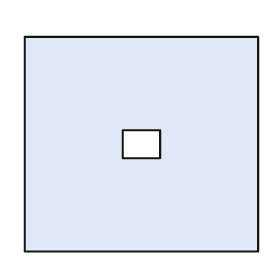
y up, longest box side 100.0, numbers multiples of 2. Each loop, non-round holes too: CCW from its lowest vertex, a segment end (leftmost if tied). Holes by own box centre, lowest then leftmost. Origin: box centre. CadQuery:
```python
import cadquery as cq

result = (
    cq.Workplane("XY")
    .moveTo(-50.0, -46.0)
    .lineTo(50.0, -46.0)
    .lineTo(50.0, 46.0)
    .lineTo(-50.0, 46.0)
    .close()
    .moveTo(-8.0, -6.0)
    .lineTo(8.0, -6.0)
    .lineTo(8.0, 6.0)
    .lineTo(-8.0, 6.0)
    .close()
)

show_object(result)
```